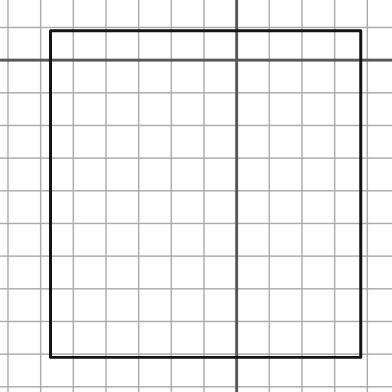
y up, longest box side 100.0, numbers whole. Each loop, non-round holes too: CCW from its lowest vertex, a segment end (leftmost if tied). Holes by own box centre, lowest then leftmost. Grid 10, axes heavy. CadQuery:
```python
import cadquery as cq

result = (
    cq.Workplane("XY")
    .moveTo(-57.0, -91.0)
    .lineTo(38.0, -91.0)
    .lineTo(38.0, 9.0)
    .lineTo(-57.0, 9.0)
    .close()
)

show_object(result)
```